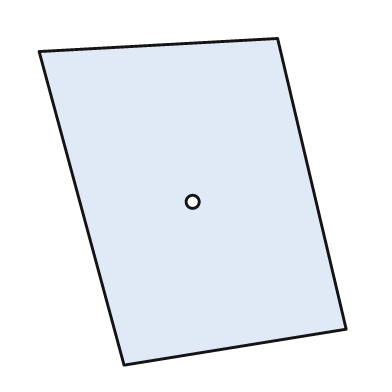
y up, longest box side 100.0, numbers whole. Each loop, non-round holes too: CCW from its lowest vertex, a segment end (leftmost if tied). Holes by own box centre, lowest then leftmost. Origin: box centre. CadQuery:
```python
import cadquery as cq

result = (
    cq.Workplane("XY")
    .moveTo(-21.0, -50.0)
    .lineTo(47.0, -39.0)
    .lineTo(26.0, 50.0)
    .lineTo(-47.0, 46.0)
    .close()
    .moveTo(0.0, 0.0)
    .circle(2.0)
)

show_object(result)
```